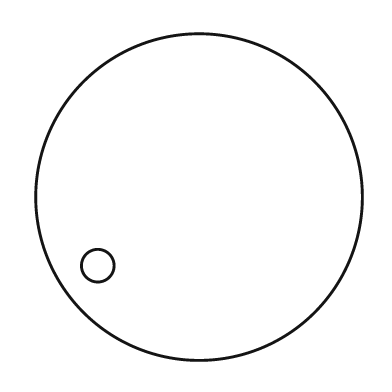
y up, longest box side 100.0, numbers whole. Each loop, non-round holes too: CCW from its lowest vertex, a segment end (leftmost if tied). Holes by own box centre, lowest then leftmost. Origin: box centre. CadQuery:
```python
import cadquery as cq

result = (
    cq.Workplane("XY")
    .moveTo(0.0, 0.0)
    .circle(50.0)
    .moveTo(-31.0, -21.0)
    .circle(5.0)
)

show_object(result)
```